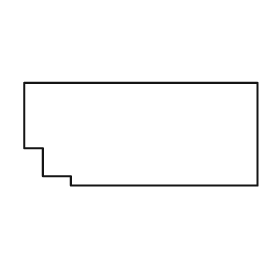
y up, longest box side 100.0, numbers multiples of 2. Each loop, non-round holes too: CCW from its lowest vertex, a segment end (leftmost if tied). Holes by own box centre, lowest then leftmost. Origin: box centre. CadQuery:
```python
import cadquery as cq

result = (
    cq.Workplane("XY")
    .moveTo(-30.0, -22.0)
    .lineTo(50.0, -22.0)
    .lineTo(50.0, 22.0)
    .lineTo(-50.0, 22.0)
    .lineTo(-50.0, -6.0)
    .lineTo(-42.0, -6.0)
    .lineTo(-42.0, -18.0)
    .lineTo(-30.0, -18.0)
    .close()
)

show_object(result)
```